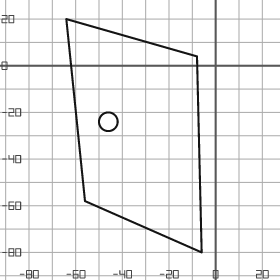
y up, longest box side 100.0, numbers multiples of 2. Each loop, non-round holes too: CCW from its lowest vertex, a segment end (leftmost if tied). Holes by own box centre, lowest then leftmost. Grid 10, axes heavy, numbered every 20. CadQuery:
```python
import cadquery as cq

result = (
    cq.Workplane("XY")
    .moveTo(-6.0, -80.0)
    .lineTo(-8.0, 4.0)
    .lineTo(-64.0, 20.0)
    .lineTo(-56.0, -58.0)
    .close()
    .moveTo(-46.0, -24.0)
    .circle(4.0)
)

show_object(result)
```